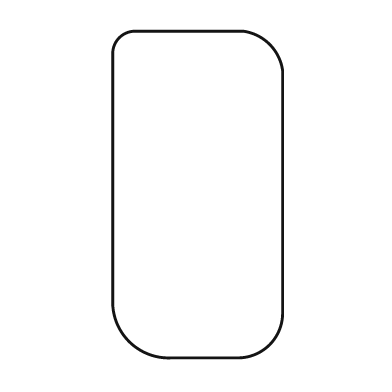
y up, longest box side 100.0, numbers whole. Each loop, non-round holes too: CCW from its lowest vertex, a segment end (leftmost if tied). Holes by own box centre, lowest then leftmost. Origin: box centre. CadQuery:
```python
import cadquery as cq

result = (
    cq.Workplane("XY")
    .moveTo(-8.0, -50.0)
    .lineTo(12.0, -50.0)
    .threePointArc((22.0, -46.0), (26.0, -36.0))
    .lineTo(26.0, 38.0)
    .threePointArc((22.0, 46.0), (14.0, 50.0))
    .lineTo(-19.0, 50.0)
    .threePointArc((-24.0, 48.0), (-26.0, 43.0))
    .lineTo(-26.0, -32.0)
    .threePointArc((-21.0, -45.0), (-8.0, -50.0))
    .close()
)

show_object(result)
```